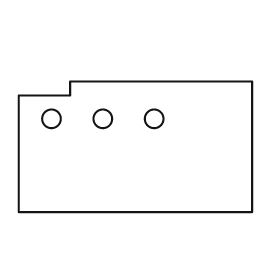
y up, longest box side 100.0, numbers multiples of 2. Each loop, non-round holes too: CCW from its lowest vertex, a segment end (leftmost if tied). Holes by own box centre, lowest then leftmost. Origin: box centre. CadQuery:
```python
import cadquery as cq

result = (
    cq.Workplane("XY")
    .moveTo(-50.0, -28.0)
    .lineTo(50.0, -28.0)
    .lineTo(50.0, 28.0)
    .lineTo(-28.0, 28.0)
    .lineTo(-28.0, 22.0)
    .lineTo(-50.0, 22.0)
    .close()
    .moveTo(-36.0, 12.0)
    .circle(4.0)
    .moveTo(-14.0, 12.0)
    .circle(4.0)
    .moveTo(8.0, 12.0)
    .circle(4.0)
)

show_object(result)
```